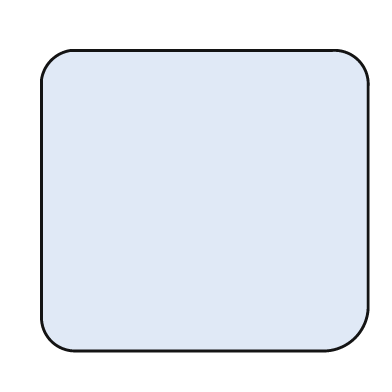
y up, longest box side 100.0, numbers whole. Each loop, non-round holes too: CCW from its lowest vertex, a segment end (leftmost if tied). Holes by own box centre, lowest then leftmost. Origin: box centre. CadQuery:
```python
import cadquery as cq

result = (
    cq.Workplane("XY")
    .moveTo(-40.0, -46.0)
    .lineTo(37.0, -46.0)
    .threePointArc((46.0, -42.0), (50.0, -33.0))
    .lineTo(50.0, 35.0)
    .threePointArc((47.0, 43.0), (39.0, 46.0))
    .lineTo(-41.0, 46.0)
    .threePointArc((-47.0, 43.0), (-50.0, 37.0))
    .lineTo(-50.0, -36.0)
    .threePointArc((-47.0, -43.0), (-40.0, -46.0))
    .close()
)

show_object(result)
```